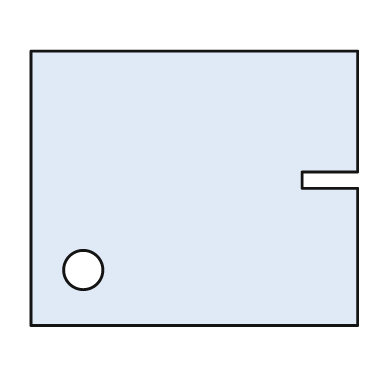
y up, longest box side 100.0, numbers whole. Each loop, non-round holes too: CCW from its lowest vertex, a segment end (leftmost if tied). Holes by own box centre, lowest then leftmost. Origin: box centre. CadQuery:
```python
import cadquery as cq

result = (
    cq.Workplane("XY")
    .moveTo(-50.0, -42.0)
    .lineTo(50.0, -42.0)
    .lineTo(50.0, 0.0)
    .lineTo(33.0, 0.0)
    .lineTo(33.0, 5.0)
    .lineTo(50.0, 5.0)
    .lineTo(50.0, 42.0)
    .lineTo(-50.0, 42.0)
    .close()
    .moveTo(-34.0, -25.0)
    .circle(6.0)
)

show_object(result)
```